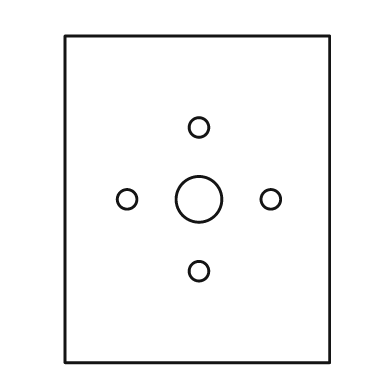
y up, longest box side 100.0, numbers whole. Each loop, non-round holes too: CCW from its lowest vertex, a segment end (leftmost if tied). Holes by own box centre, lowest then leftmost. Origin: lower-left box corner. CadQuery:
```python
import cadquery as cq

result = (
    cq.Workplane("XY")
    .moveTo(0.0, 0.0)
    .lineTo(81.0, 0.0)
    .lineTo(81.0, 100.0)
    .lineTo(0.0, 100.0)
    .close()
    .moveTo(41.0, 28.0)
    .circle(3.0)
    .moveTo(19.0, 50.0)
    .circle(3.0)
    .moveTo(41.0, 50.0)
    .circle(7.0)
    .moveTo(63.0, 50.0)
    .circle(3.0)
    .moveTo(41.0, 72.0)
    .circle(3.0)
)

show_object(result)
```